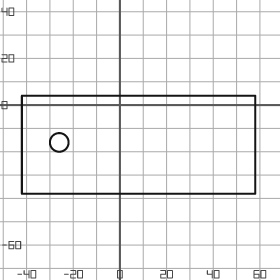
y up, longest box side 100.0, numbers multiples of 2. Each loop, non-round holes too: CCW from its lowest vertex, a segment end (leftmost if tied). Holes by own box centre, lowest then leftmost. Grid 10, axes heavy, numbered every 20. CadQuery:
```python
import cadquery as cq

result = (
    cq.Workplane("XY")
    .moveTo(-42.0, -38.0)
    .lineTo(58.0, -38.0)
    .lineTo(58.0, 4.0)
    .lineTo(-42.0, 4.0)
    .close()
    .moveTo(-26.0, -16.0)
    .circle(4.0)
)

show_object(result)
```